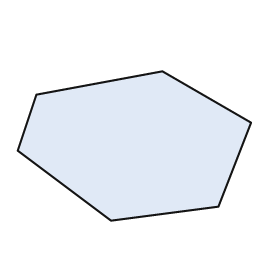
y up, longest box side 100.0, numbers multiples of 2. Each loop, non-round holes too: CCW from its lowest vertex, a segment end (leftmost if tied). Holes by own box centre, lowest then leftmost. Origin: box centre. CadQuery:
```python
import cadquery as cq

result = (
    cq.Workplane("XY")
    .moveTo(-10.0, -32.0)
    .lineTo(36.0, -26.0)
    .lineTo(50.0, 10.0)
    .lineTo(12.0, 32.0)
    .lineTo(-42.0, 22.0)
    .lineTo(-50.0, -2.0)
    .close()
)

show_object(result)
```